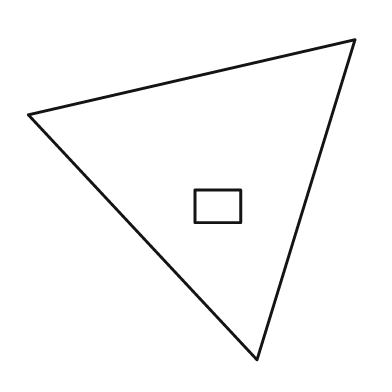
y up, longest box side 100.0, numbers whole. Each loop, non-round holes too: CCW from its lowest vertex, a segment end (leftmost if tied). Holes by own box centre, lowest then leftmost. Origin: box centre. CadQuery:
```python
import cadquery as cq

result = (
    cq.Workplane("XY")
    .moveTo(20.0, -49.0)
    .lineTo(50.0, 49.0)
    .lineTo(-50.0, 26.0)
    .close()
    .moveTo(1.0, -7.0)
    .lineTo(15.0, -7.0)
    .lineTo(15.0, 3.0)
    .lineTo(1.0, 3.0)
    .close()
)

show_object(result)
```